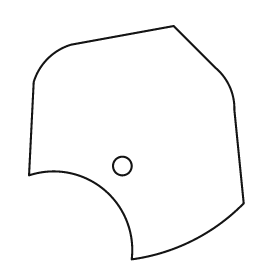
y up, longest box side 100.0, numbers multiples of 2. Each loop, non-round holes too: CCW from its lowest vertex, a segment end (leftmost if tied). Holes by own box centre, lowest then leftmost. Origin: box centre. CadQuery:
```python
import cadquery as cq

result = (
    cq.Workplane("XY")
    .moveTo(-2.0, -50.0)
    .threePointArc((24.0, -42.0), (46.0, -26.0))
    .lineTo(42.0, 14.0)
    .threePointArc((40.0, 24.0), (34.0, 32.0))
    .lineTo(16.0, 50.0)
    .lineTo(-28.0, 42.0)
    .threePointArc((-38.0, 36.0), (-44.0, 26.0))
    .lineTo(-46.0, -14.0)
    .threePointArc((-14.0, -20.0), (-2.0, -50.0))
    .close()
    .moveTo(-6.0, -10.0)
    .circle(4.0)
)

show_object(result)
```